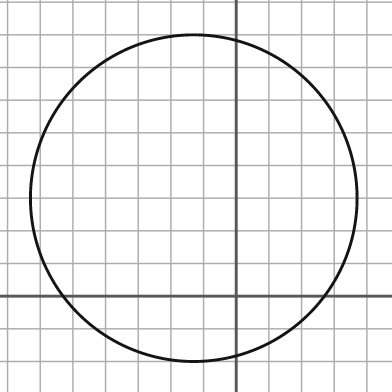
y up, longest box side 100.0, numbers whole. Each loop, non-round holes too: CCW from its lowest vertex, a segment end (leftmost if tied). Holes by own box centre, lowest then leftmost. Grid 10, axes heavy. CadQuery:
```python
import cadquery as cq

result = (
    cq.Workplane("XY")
    .moveTo(-13.0, 30.0)
    .circle(50.0)
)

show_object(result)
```